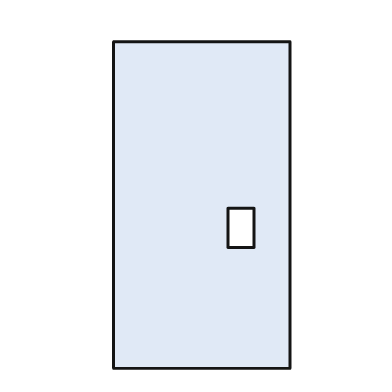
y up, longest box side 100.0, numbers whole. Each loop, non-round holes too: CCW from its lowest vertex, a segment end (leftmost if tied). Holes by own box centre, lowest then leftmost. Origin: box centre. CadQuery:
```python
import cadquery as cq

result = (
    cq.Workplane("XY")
    .moveTo(-27.0, -50.0)
    .lineTo(27.0, -50.0)
    .lineTo(27.0, 50.0)
    .lineTo(-27.0, 50.0)
    .close()
    .moveTo(8.0, -13.0)
    .lineTo(16.0, -13.0)
    .lineTo(16.0, -1.0)
    .lineTo(8.0, -1.0)
    .close()
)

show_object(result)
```